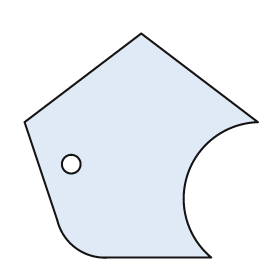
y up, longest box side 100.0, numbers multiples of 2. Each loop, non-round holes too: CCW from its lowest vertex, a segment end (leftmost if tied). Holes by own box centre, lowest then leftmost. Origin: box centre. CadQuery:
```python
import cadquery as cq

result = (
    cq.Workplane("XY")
    .moveTo(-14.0, -48.0)
    .lineTo(30.0, -48.0)
    .threePointArc((20.0, -12.0), (50.0, 10.0))
    .lineTo(0.0, 48.0)
    .lineTo(-50.0, 10.0)
    .lineTo(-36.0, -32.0)
    .threePointArc((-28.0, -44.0), (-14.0, -48.0))
    .close()
    .moveTo(-30.0, -8.0)
    .circle(4.0)
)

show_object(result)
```